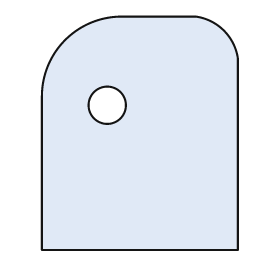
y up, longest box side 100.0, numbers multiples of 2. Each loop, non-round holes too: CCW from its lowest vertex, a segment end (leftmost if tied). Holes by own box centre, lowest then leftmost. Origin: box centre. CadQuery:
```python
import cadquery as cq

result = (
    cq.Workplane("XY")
    .moveTo(-42.0, -50.0)
    .lineTo(42.0, -50.0)
    .lineTo(42.0, 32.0)
    .threePointArc((36.0, 44.0), (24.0, 50.0))
    .lineTo(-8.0, 50.0)
    .threePointArc((-32.0, 40.0), (-42.0, 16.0))
    .close()
    .moveTo(-14.0, 12.0)
    .circle(8.0)
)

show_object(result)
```